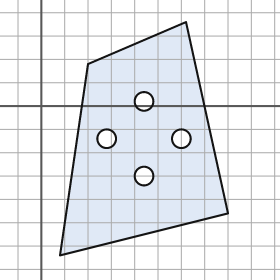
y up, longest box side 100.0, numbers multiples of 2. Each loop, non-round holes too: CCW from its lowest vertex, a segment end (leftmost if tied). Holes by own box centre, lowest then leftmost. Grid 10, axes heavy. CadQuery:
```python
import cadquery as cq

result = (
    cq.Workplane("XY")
    .moveTo(8.0, -64.0)
    .lineTo(80.0, -46.0)
    .lineTo(62.0, 36.0)
    .lineTo(20.0, 18.0)
    .close()
    .moveTo(44.0, -30.0)
    .circle(4.0)
    .moveTo(28.0, -14.0)
    .circle(4.0)
    .moveTo(60.0, -14.0)
    .circle(4.0)
    .moveTo(44.0, 2.0)
    .circle(4.0)
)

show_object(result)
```